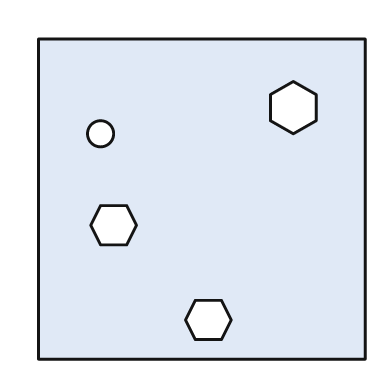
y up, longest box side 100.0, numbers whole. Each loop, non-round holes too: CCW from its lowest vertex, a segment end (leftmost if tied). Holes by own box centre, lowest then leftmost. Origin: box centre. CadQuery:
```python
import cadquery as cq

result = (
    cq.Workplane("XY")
    .moveTo(-50.0, -49.0)
    .lineTo(50.0, -49.0)
    .lineTo(50.0, 49.0)
    .lineTo(-50.0, 49.0)
    .close()
    .moveTo(-2.0, -43.0)
    .lineTo(6.0, -43.0)
    .lineTo(9.0, -37.0)
    .lineTo(6.0, -31.0)
    .lineTo(-2.0, -31.0)
    .lineTo(-5.0, -37.0)
    .close()
    .moveTo(-31.0, -14.0)
    .lineTo(-23.0, -14.0)
    .lineTo(-20.0, -8.0)
    .lineTo(-23.0, -2.0)
    .lineTo(-31.0, -2.0)
    .lineTo(-34.0, -8.0)
    .close()
    .moveTo(-31.0, 20.0)
    .circle(4.0)
    .moveTo(28.0, 20.0)
    .lineTo(35.0, 24.0)
    .lineTo(35.0, 32.0)
    .lineTo(28.0, 36.0)
    .lineTo(21.0, 32.0)
    .lineTo(21.0, 24.0)
    .close()
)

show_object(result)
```